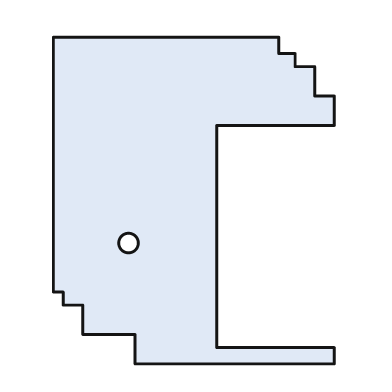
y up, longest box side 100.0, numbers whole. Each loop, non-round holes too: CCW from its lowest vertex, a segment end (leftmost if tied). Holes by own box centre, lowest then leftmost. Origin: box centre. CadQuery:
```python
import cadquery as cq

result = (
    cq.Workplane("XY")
    .moveTo(-18.0, -50.0)
    .lineTo(43.0, -50.0)
    .lineTo(43.0, -45.0)
    .lineTo(7.0, -45.0)
    .lineTo(7.0, 23.0)
    .lineTo(43.0, 23.0)
    .lineTo(43.0, 32.0)
    .lineTo(37.0, 32.0)
    .lineTo(37.0, 41.0)
    .lineTo(31.0, 41.0)
    .lineTo(31.0, 45.0)
    .lineTo(26.0, 45.0)
    .lineTo(26.0, 50.0)
    .lineTo(-43.0, 50.0)
    .lineTo(-43.0, -28.0)
    .lineTo(-40.0, -28.0)
    .lineTo(-40.0, -32.0)
    .lineTo(-34.0, -32.0)
    .lineTo(-34.0, -41.0)
    .lineTo(-18.0, -41.0)
    .close()
    .moveTo(-20.0, -13.0)
    .circle(3.0)
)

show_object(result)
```